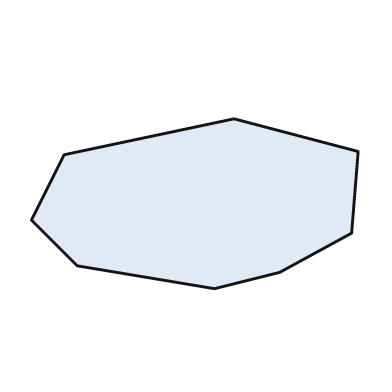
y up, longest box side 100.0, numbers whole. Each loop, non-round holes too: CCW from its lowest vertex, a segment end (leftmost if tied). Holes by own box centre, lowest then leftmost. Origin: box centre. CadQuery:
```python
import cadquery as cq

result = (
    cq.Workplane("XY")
    .moveTo(6.0, -26.0)
    .lineTo(26.0, -21.0)
    .lineTo(48.0, -9.0)
    .lineTo(50.0, 16.0)
    .lineTo(12.0, 26.0)
    .lineTo(-40.0, 15.0)
    .lineTo(-50.0, -5.0)
    .lineTo(-36.0, -19.0)
    .close()
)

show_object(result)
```